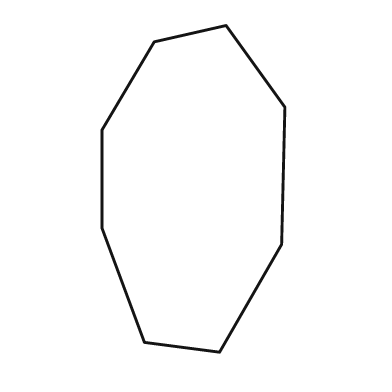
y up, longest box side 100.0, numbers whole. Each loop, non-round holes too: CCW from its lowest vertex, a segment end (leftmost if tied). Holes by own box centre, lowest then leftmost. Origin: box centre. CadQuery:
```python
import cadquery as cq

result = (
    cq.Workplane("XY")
    .moveTo(8.0, -50.0)
    .lineTo(27.0, -17.0)
    .lineTo(28.0, 25.0)
    .lineTo(10.0, 50.0)
    .lineTo(-12.0, 45.0)
    .lineTo(-28.0, 18.0)
    .lineTo(-28.0, -12.0)
    .lineTo(-15.0, -47.0)
    .close()
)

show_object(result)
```